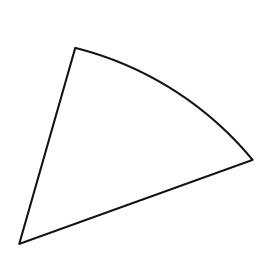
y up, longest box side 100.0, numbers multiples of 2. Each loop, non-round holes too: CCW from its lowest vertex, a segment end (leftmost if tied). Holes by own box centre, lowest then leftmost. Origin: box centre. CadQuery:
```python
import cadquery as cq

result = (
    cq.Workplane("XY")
    .moveTo(-50.0, -42.0)
    .lineTo(50.0, -6.0)
    .threePointArc((16.0, 24.0), (-26.0, 42.0))
    .close()
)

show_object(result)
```